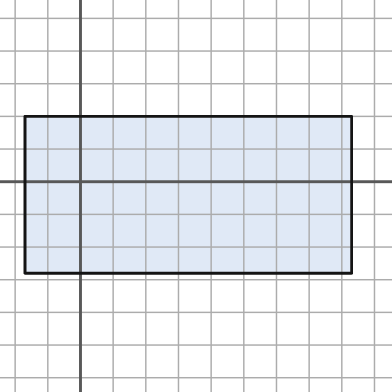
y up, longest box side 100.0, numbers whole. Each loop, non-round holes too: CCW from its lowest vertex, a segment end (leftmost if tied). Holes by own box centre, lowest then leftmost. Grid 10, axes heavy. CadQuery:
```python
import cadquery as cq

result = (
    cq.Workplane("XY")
    .moveTo(-17.0, -28.0)
    .lineTo(83.0, -28.0)
    .lineTo(83.0, 20.0)
    .lineTo(-17.0, 20.0)
    .close()
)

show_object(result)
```